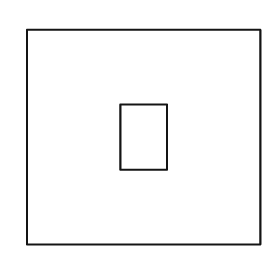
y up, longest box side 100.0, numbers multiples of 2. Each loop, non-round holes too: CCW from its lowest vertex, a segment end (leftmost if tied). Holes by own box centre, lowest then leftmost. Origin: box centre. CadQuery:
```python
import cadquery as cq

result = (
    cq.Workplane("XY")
    .moveTo(-50.0, -46.0)
    .lineTo(50.0, -46.0)
    .lineTo(50.0, 46.0)
    .lineTo(-50.0, 46.0)
    .close()
    .moveTo(-10.0, -14.0)
    .lineTo(10.0, -14.0)
    .lineTo(10.0, 14.0)
    .lineTo(-10.0, 14.0)
    .close()
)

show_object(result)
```